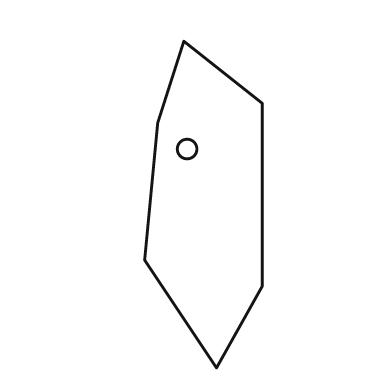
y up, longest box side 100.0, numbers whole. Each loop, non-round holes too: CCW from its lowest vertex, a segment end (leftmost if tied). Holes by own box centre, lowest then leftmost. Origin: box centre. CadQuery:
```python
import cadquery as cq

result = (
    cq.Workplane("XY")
    .moveTo(4.0, -50.0)
    .lineTo(18.0, -25.0)
    .lineTo(18.0, 31.0)
    .lineTo(-6.0, 50.0)
    .lineTo(-14.0, 25.0)
    .lineTo(-18.0, -17.0)
    .close()
    .moveTo(-5.0, 17.0)
    .circle(3.0)
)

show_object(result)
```